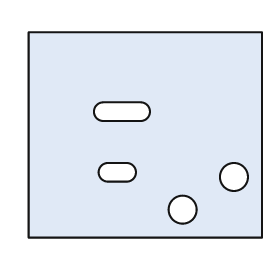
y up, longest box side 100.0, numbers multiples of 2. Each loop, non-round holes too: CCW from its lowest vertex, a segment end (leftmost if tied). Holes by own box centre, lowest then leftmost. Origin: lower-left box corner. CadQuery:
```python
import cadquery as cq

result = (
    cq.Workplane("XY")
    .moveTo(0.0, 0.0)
    .lineTo(100.0, 0.0)
    .lineTo(100.0, 88.0)
    .lineTo(0.0, 88.0)
    .close()
    .moveTo(66.0, 12.0)
    .circle(6.0)
    .moveTo(88.0, 26.0)
    .circle(6.0)
    .moveTo(34.0, 24.0)
    .lineTo(42.0, 24.0)
    .threePointArc((46.0, 28.0), (42.0, 32.0))
    .lineTo(34.0, 32.0)
    .threePointArc((30.0, 28.0), (34.0, 24.0))
    .close()
    .moveTo(32.0, 50.0)
    .lineTo(48.0, 50.0)
    .threePointArc((52.0, 54.0), (48.0, 58.0))
    .lineTo(32.0, 58.0)
    .threePointArc((28.0, 54.0), (32.0, 50.0))
    .close()
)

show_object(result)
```